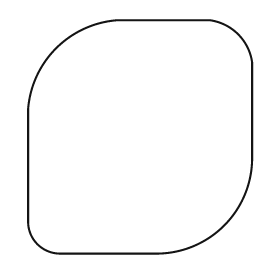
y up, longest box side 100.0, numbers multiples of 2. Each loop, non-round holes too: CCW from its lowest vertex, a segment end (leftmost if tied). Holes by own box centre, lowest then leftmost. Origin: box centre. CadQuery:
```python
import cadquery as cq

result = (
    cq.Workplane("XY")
    .moveTo(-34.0, -50.0)
    .lineTo(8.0, -50.0)
    .threePointArc((36.0, -38.0), (48.0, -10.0))
    .lineTo(48.0, 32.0)
    .threePointArc((42.0, 44.0), (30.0, 50.0))
    .lineTo(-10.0, 50.0)
    .threePointArc((-36.0, 38.0), (-48.0, 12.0))
    .lineTo(-48.0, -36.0)
    .threePointArc((-44.0, -46.0), (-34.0, -50.0))
    .close()
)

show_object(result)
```